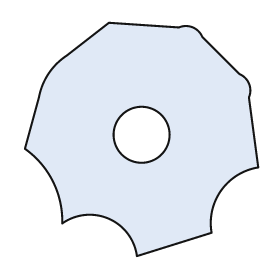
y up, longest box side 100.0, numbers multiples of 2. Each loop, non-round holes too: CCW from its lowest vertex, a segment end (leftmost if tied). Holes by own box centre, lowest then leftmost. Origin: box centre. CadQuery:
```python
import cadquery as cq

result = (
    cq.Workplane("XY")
    .moveTo(-2.0, -50.0)
    .lineTo(30.0, -40.0)
    .threePointArc((34.0, -22.0), (50.0, -12.0))
    .lineTo(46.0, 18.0)
    .threePointArc((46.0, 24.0), (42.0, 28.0))
    .lineTo(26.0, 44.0)
    .threePointArc((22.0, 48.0), (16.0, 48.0))
    .lineTo(-14.0, 50.0)
    .lineTo(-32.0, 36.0)
    .threePointArc((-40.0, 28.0), (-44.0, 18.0))
    .lineTo(-50.0, -4.0)
    .threePointArc((-38.0, -18.0), (-34.0, -36.0))
    .threePointArc((-14.0, -34.0), (-2.0, -50.0))
    .close()
    .moveTo(0.0, 2.0)
    .circle(12.0)
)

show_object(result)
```